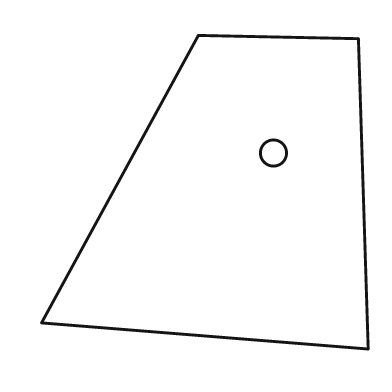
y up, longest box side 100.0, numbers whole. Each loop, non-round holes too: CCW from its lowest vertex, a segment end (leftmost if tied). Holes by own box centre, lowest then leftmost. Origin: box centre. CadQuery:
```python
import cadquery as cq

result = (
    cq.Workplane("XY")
    .moveTo(50.0, -48.0)
    .lineTo(47.0, 47.0)
    .lineTo(-2.0, 48.0)
    .lineTo(-50.0, -40.0)
    .close()
    .moveTo(21.0, 12.0)
    .circle(4.0)
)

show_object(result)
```